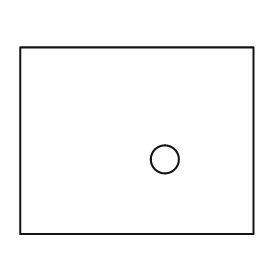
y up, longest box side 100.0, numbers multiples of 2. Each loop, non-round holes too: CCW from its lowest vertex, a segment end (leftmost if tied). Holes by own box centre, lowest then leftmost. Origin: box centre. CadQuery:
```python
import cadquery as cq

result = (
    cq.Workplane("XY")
    .moveTo(-50.0, -40.0)
    .lineTo(50.0, -40.0)
    .lineTo(50.0, 40.0)
    .lineTo(-50.0, 40.0)
    .close()
    .moveTo(12.0, -8.0)
    .circle(6.0)
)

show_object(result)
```